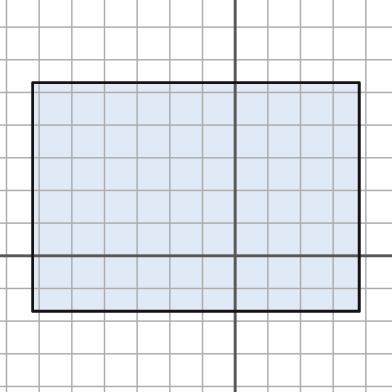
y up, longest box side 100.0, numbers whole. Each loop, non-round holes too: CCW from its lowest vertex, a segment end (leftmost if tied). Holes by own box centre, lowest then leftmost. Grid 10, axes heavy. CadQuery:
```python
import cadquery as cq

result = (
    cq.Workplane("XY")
    .moveTo(-62.0, -17.0)
    .lineTo(38.0, -17.0)
    .lineTo(38.0, 53.0)
    .lineTo(-62.0, 53.0)
    .close()
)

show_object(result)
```